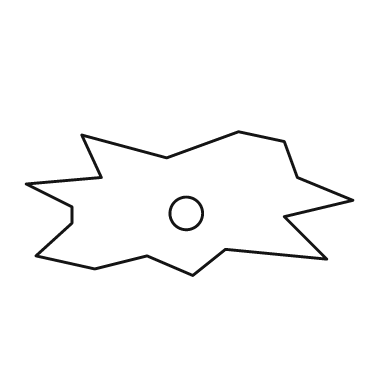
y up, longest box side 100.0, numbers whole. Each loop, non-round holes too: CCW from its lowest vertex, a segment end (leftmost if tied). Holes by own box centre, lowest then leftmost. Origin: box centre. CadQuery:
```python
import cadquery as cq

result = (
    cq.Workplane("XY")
    .moveTo(1.0, -22.0)
    .lineTo(11.0, -14.0)
    .lineTo(42.0, -17.0)
    .lineTo(29.0, -4.0)
    .lineTo(50.0, 1.0)
    .lineTo(33.0, 8.0)
    .lineTo(29.0, 19.0)
    .lineTo(15.0, 22.0)
    .lineTo(-7.0, 14.0)
    .lineTo(-33.0, 21.0)
    .lineTo(-27.0, 8.0)
    .lineTo(-50.0, 6.0)
    .lineTo(-36.0, -1.0)
    .lineTo(-36.0, -6.0)
    .lineTo(-47.0, -16.0)
    .lineTo(-29.0, -20.0)
    .lineTo(-13.0, -16.0)
    .close()
    .moveTo(-1.0, -3.0)
    .circle(5.0)
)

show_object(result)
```